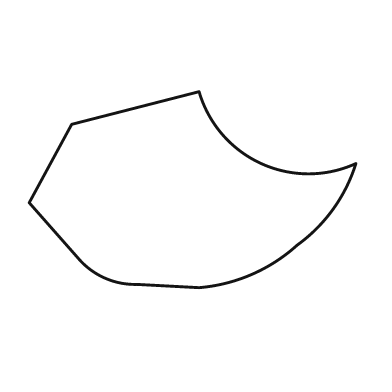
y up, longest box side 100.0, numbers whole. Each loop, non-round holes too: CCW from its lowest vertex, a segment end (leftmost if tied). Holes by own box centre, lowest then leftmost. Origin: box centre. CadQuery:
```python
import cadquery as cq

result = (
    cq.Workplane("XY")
    .moveTo(2.0, -30.0)
    .threePointArc((18.0, -26.0), (32.0, -17.0))
    .threePointArc((43.0, -6.0), (50.0, 8.0))
    .threePointArc((21.0, 8.0), (2.0, 30.0))
    .lineTo(-37.0, 20.0)
    .lineTo(-50.0, -4.0)
    .lineTo(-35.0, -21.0)
    .threePointArc((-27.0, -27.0), (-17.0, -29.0))
    .close()
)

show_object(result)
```